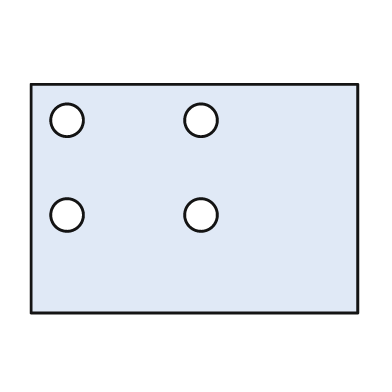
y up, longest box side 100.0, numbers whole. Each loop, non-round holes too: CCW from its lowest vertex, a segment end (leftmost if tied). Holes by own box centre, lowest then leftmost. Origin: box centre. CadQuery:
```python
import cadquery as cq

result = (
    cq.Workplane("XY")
    .moveTo(-50.0, -35.0)
    .lineTo(50.0, -35.0)
    .lineTo(50.0, 35.0)
    .lineTo(-50.0, 35.0)
    .close()
    .moveTo(-39.0, -5.0)
    .circle(5.0)
    .moveTo(2.0, -5.0)
    .circle(5.0)
    .moveTo(-39.0, 24.0)
    .circle(5.0)
    .moveTo(2.0, 24.0)
    .circle(5.0)
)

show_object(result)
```